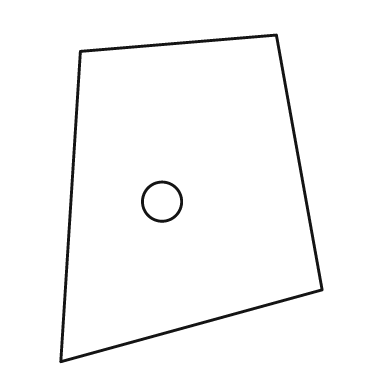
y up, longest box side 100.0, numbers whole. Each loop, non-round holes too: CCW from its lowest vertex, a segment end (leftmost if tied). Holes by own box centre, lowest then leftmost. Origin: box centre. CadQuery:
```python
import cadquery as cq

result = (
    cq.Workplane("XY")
    .moveTo(-40.0, -50.0)
    .lineTo(40.0, -28.0)
    .lineTo(26.0, 50.0)
    .lineTo(-34.0, 45.0)
    .close()
    .moveTo(-9.0, -1.0)
    .circle(6.0)
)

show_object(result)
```